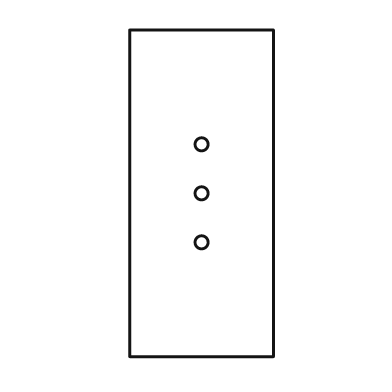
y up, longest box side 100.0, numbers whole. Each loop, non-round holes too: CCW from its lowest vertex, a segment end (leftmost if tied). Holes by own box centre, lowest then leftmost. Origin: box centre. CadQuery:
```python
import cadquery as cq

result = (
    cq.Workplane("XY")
    .moveTo(-22.0, -50.0)
    .lineTo(22.0, -50.0)
    .lineTo(22.0, 50.0)
    .lineTo(-22.0, 50.0)
    .close()
    .moveTo(0.0, -15.0)
    .circle(2.0)
    .moveTo(0.0, 0.0)
    .circle(2.0)
    .moveTo(0.0, 15.0)
    .circle(2.0)
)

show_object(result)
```